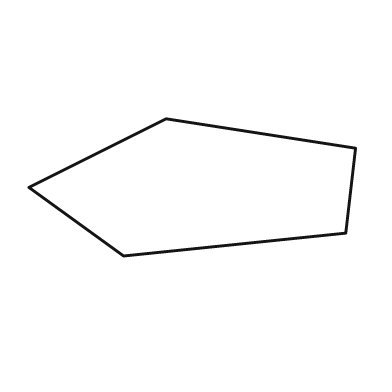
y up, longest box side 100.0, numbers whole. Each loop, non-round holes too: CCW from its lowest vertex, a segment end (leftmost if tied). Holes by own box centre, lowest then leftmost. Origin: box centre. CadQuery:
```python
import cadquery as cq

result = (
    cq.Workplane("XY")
    .moveTo(-21.0, -21.0)
    .lineTo(47.0, -14.0)
    .lineTo(50.0, 12.0)
    .lineTo(-8.0, 21.0)
    .lineTo(-50.0, 0.0)
    .close()
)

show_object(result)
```